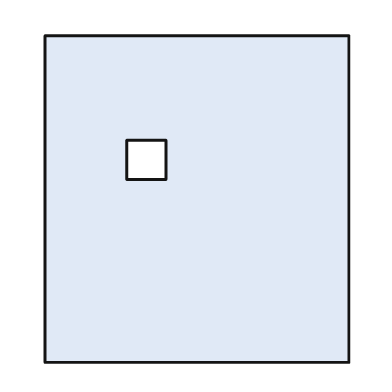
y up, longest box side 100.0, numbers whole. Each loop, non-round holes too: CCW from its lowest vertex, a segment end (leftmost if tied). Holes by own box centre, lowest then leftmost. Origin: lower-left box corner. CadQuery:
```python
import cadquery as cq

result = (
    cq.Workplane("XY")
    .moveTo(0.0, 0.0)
    .lineTo(93.0, 0.0)
    .lineTo(93.0, 100.0)
    .lineTo(0.0, 100.0)
    .close()
    .moveTo(25.0, 56.0)
    .lineTo(37.0, 56.0)
    .lineTo(37.0, 68.0)
    .lineTo(25.0, 68.0)
    .close()
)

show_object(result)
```